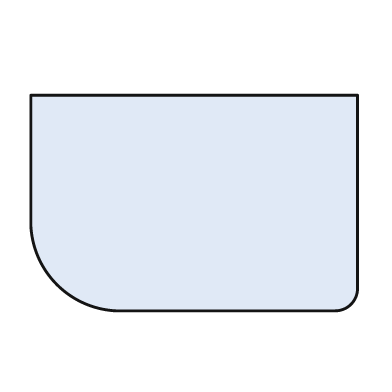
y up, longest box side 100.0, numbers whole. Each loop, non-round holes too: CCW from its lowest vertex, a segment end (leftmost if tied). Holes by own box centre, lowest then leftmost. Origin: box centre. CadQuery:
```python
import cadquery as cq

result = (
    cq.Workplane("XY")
    .moveTo(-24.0, -33.0)
    .lineTo(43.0, -33.0)
    .threePointArc((48.0, -31.0), (50.0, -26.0))
    .lineTo(50.0, 33.0)
    .lineTo(-50.0, 33.0)
    .lineTo(-50.0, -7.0)
    .threePointArc((-42.0, -25.0), (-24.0, -33.0))
    .close()
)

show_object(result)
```